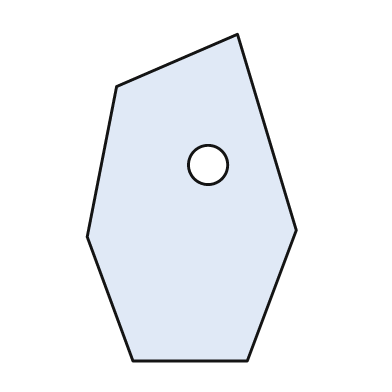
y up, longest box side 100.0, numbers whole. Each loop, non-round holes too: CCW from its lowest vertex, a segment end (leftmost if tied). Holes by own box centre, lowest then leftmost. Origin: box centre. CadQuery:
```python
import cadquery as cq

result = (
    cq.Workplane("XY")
    .moveTo(-18.0, -50.0)
    .lineTo(17.0, -50.0)
    .lineTo(32.0, -10.0)
    .lineTo(14.0, 50.0)
    .lineTo(-23.0, 34.0)
    .lineTo(-32.0, -12.0)
    .close()
    .moveTo(5.0, 10.0)
    .circle(6.0)
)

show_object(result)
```